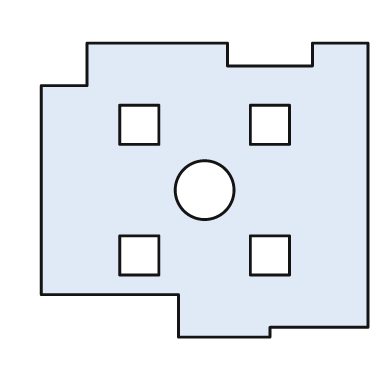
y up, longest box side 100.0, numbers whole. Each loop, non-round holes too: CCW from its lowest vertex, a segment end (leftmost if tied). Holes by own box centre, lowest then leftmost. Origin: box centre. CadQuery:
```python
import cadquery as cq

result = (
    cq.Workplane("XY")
    .moveTo(-8.0, -45.0)
    .lineTo(20.0, -45.0)
    .lineTo(20.0, -42.0)
    .lineTo(50.0, -42.0)
    .lineTo(50.0, 45.0)
    .lineTo(33.0, 45.0)
    .lineTo(33.0, 38.0)
    .lineTo(7.0, 38.0)
    .lineTo(7.0, 45.0)
    .lineTo(-36.0, 45.0)
    .lineTo(-36.0, 32.0)
    .lineTo(-50.0, 32.0)
    .lineTo(-50.0, -32.0)
    .lineTo(-8.0, -32.0)
    .close()
    .moveTo(-26.0, -26.0)
    .lineTo(-14.0, -26.0)
    .lineTo(-14.0, -14.0)
    .lineTo(-26.0, -14.0)
    .close()
    .moveTo(14.0, -26.0)
    .lineTo(26.0, -26.0)
    .lineTo(26.0, -14.0)
    .lineTo(14.0, -14.0)
    .close()
    .moveTo(0.0, 0.0)
    .circle(9.0)
    .moveTo(-26.0, 14.0)
    .lineTo(-14.0, 14.0)
    .lineTo(-14.0, 26.0)
    .lineTo(-26.0, 26.0)
    .close()
    .moveTo(14.0, 14.0)
    .lineTo(26.0, 14.0)
    .lineTo(26.0, 26.0)
    .lineTo(14.0, 26.0)
    .close()
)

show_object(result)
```